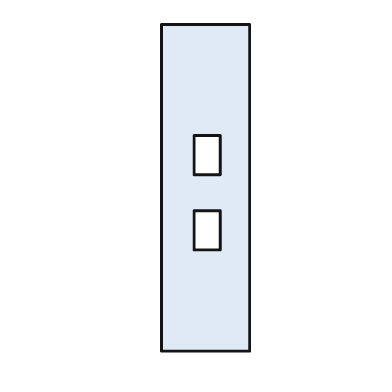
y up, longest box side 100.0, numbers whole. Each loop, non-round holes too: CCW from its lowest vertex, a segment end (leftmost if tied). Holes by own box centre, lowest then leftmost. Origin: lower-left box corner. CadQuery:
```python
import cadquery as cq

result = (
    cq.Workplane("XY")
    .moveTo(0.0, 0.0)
    .lineTo(27.0, 0.0)
    .lineTo(27.0, 100.0)
    .lineTo(0.0, 100.0)
    .close()
    .moveTo(10.0, 31.0)
    .lineTo(18.0, 31.0)
    .lineTo(18.0, 43.0)
    .lineTo(10.0, 43.0)
    .close()
    .moveTo(10.0, 54.0)
    .lineTo(18.0, 54.0)
    .lineTo(18.0, 66.0)
    .lineTo(10.0, 66.0)
    .close()
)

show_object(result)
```